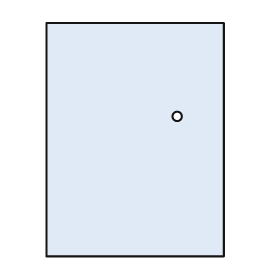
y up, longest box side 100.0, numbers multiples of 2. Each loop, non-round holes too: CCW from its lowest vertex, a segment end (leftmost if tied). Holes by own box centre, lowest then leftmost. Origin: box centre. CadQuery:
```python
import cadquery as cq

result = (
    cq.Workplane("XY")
    .moveTo(-38.0, -50.0)
    .lineTo(38.0, -50.0)
    .lineTo(38.0, 50.0)
    .lineTo(-38.0, 50.0)
    .close()
    .moveTo(18.0, 10.0)
    .circle(2.0)
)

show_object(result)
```